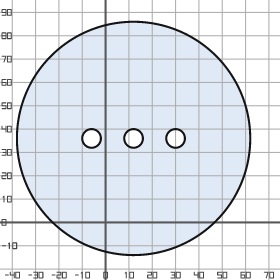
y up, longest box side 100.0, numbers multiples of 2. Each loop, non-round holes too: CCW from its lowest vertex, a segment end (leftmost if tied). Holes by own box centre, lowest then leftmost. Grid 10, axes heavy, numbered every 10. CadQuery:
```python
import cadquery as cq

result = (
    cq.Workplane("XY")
    .moveTo(12.0, 36.0)
    .circle(50.0)
    .moveTo(-6.0, 36.0)
    .circle(4.0)
    .moveTo(12.0, 36.0)
    .circle(4.0)
    .moveTo(30.0, 36.0)
    .circle(4.0)
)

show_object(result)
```